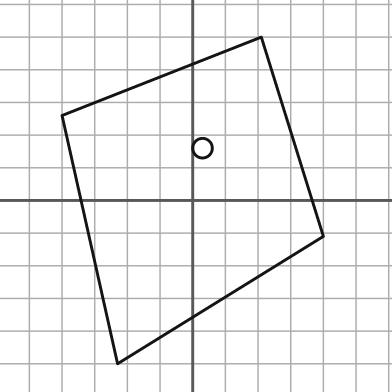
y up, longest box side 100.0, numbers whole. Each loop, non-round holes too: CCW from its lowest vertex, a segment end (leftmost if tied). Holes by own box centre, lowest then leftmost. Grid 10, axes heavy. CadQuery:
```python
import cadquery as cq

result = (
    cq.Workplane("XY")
    .moveTo(-23.0, -50.0)
    .lineTo(40.0, -11.0)
    .lineTo(21.0, 50.0)
    .lineTo(-40.0, 26.0)
    .close()
    .moveTo(3.0, 16.0)
    .circle(3.0)
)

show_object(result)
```